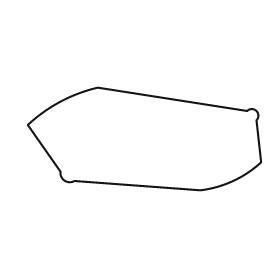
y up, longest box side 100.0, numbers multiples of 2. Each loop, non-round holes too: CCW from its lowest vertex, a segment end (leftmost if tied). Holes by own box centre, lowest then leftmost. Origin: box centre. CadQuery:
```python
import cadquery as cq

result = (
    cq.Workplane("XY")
    .moveTo(24.0, -22.0)
    .threePointArc((38.0, -18.0), (50.0, -10.0))
    .lineTo(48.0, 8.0)
    .threePointArc((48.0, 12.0), (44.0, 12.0))
    .lineTo(-20.0, 22.0)
    .threePointArc((-36.0, 16.0), (-50.0, 6.0))
    .lineTo(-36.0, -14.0)
    .threePointArc((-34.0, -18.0), (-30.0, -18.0))
    .close()
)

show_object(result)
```